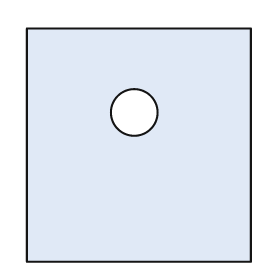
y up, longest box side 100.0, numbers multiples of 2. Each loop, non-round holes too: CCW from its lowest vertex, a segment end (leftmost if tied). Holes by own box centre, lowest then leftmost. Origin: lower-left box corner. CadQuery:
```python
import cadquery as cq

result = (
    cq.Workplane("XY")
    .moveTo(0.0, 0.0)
    .lineTo(96.0, 0.0)
    .lineTo(96.0, 100.0)
    .lineTo(0.0, 100.0)
    .close()
    .moveTo(46.0, 64.0)
    .circle(10.0)
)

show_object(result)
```